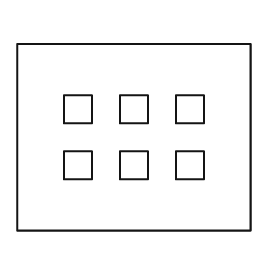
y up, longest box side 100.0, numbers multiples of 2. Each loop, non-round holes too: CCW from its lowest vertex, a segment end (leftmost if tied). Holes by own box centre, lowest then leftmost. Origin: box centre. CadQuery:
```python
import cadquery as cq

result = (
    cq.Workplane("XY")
    .moveTo(-50.0, -40.0)
    .lineTo(50.0, -40.0)
    .lineTo(50.0, 40.0)
    .lineTo(-50.0, 40.0)
    .close()
    .moveTo(-30.0, -18.0)
    .lineTo(-18.0, -18.0)
    .lineTo(-18.0, -6.0)
    .lineTo(-30.0, -6.0)
    .close()
    .moveTo(-6.0, -18.0)
    .lineTo(6.0, -18.0)
    .lineTo(6.0, -6.0)
    .lineTo(-6.0, -6.0)
    .close()
    .moveTo(18.0, -18.0)
    .lineTo(30.0, -18.0)
    .lineTo(30.0, -6.0)
    .lineTo(18.0, -6.0)
    .close()
    .moveTo(-30.0, 6.0)
    .lineTo(-18.0, 6.0)
    .lineTo(-18.0, 18.0)
    .lineTo(-30.0, 18.0)
    .close()
    .moveTo(-6.0, 6.0)
    .lineTo(6.0, 6.0)
    .lineTo(6.0, 18.0)
    .lineTo(-6.0, 18.0)
    .close()
    .moveTo(18.0, 6.0)
    .lineTo(30.0, 6.0)
    .lineTo(30.0, 18.0)
    .lineTo(18.0, 18.0)
    .close()
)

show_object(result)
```